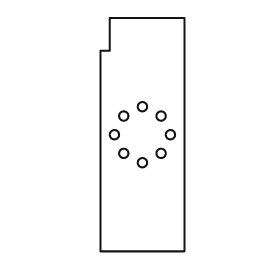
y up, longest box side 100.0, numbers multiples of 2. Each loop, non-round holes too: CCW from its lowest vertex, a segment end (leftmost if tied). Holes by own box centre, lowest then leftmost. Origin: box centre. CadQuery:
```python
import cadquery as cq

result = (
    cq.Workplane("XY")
    .moveTo(-18.0, -50.0)
    .lineTo(18.0, -50.0)
    .lineTo(18.0, 50.0)
    .lineTo(-14.0, 50.0)
    .lineTo(-14.0, 36.0)
    .lineTo(-18.0, 36.0)
    .close()
    .moveTo(0.0, -12.0)
    .circle(2.0)
    .moveTo(-8.0, -8.0)
    .circle(2.0)
    .moveTo(8.0, -8.0)
    .circle(2.0)
    .moveTo(-12.0, 0.0)
    .circle(2.0)
    .moveTo(12.0, 0.0)
    .circle(2.0)
    .moveTo(-8.0, 8.0)
    .circle(2.0)
    .moveTo(8.0, 8.0)
    .circle(2.0)
    .moveTo(0.0, 12.0)
    .circle(2.0)
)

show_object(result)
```